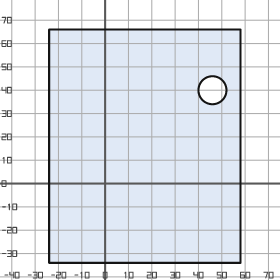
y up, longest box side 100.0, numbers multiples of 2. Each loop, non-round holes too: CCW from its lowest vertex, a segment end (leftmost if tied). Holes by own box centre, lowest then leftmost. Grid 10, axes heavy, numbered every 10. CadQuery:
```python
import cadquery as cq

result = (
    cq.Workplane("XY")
    .moveTo(-24.0, -34.0)
    .lineTo(58.0, -34.0)
    .lineTo(58.0, 66.0)
    .lineTo(-24.0, 66.0)
    .close()
    .moveTo(46.0, 40.0)
    .circle(6.0)
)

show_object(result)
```